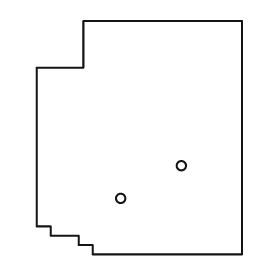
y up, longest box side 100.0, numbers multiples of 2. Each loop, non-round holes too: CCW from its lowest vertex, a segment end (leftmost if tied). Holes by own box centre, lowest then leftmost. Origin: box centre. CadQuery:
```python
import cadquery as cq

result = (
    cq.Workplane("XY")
    .moveTo(-20.0, -50.0)
    .lineTo(44.0, -50.0)
    .lineTo(44.0, 50.0)
    .lineTo(-24.0, 50.0)
    .lineTo(-24.0, 30.0)
    .lineTo(-44.0, 30.0)
    .lineTo(-44.0, -38.0)
    .lineTo(-38.0, -38.0)
    .lineTo(-38.0, -42.0)
    .lineTo(-26.0, -42.0)
    .lineTo(-26.0, -46.0)
    .lineTo(-20.0, -46.0)
    .close()
    .moveTo(-8.0, -26.0)
    .circle(2.0)
    .moveTo(18.0, -12.0)
    .circle(2.0)
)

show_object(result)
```